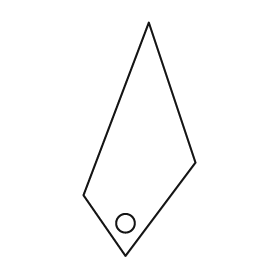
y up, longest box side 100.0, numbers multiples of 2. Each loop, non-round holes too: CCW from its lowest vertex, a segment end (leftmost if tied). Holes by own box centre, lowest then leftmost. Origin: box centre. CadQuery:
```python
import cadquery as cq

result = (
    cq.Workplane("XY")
    .moveTo(-6.0, -50.0)
    .lineTo(24.0, -10.0)
    .lineTo(4.0, 50.0)
    .lineTo(-24.0, -24.0)
    .close()
    .moveTo(-6.0, -36.0)
    .circle(4.0)
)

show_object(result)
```